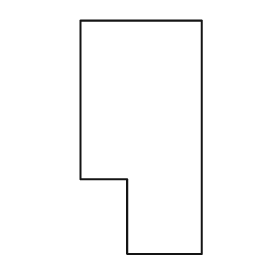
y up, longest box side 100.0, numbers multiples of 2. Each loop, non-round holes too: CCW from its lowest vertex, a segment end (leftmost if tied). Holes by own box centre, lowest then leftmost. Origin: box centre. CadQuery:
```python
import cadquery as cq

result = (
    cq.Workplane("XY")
    .moveTo(-6.0, -50.0)
    .lineTo(26.0, -50.0)
    .lineTo(26.0, 50.0)
    .lineTo(-26.0, 50.0)
    .lineTo(-26.0, -18.0)
    .lineTo(-6.0, -18.0)
    .close()
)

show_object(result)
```